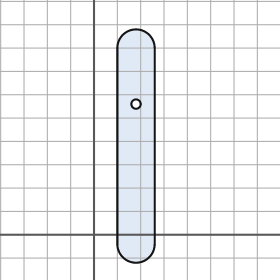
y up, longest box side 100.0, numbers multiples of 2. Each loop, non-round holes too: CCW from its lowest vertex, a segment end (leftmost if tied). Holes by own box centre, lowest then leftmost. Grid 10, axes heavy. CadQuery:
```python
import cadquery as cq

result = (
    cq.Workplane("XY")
    .moveTo(10.0, -4.0)
    .threePointArc((18.0, -12.0), (26.0, -4.0))
    .lineTo(26.0, 80.0)
    .threePointArc((18.0, 88.0), (10.0, 80.0))
    .close()
    .moveTo(18.0, 56.0)
    .circle(2.0)
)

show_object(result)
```